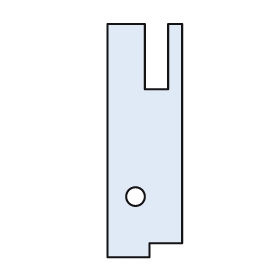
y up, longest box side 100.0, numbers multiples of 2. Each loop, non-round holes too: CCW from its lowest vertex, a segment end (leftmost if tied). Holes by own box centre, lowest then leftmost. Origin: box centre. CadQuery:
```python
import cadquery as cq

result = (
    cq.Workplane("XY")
    .moveTo(-16.0, -50.0)
    .lineTo(2.0, -50.0)
    .lineTo(2.0, -44.0)
    .lineTo(16.0, -44.0)
    .lineTo(16.0, 50.0)
    .lineTo(10.0, 50.0)
    .lineTo(10.0, 22.0)
    .lineTo(0.0, 22.0)
    .lineTo(0.0, 50.0)
    .lineTo(-16.0, 50.0)
    .close()
    .moveTo(-4.0, -24.0)
    .circle(4.0)
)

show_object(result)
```